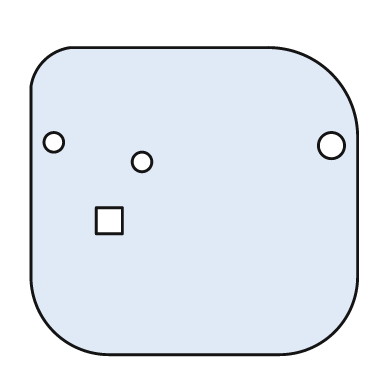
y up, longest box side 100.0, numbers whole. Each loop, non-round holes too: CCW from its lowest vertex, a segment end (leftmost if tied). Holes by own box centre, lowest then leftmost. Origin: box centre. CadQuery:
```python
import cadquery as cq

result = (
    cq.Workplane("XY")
    .moveTo(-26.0, -47.0)
    .lineTo(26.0, -47.0)
    .threePointArc((43.0, -40.0), (50.0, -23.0))
    .lineTo(50.0, 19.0)
    .threePointArc((42.0, 39.0), (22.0, 47.0))
    .lineTo(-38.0, 47.0)
    .threePointArc((-46.0, 43.0), (-50.0, 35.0))
    .lineTo(-50.0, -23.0)
    .threePointArc((-43.0, -40.0), (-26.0, -47.0))
    .close()
    .moveTo(-30.0, -10.0)
    .lineTo(-22.0, -10.0)
    .lineTo(-22.0, -2.0)
    .lineTo(-30.0, -2.0)
    .close()
    .moveTo(-16.0, 12.0)
    .circle(3.0)
    .moveTo(42.0, 17.0)
    .circle(4.0)
    .moveTo(-43.0, 18.0)
    .circle(3.0)
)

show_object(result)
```